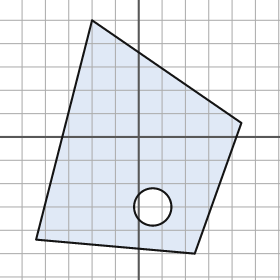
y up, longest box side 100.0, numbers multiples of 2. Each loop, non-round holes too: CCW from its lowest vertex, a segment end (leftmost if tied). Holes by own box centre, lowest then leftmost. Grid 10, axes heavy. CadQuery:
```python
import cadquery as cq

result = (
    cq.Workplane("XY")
    .moveTo(24.0, -50.0)
    .lineTo(44.0, 6.0)
    .lineTo(-20.0, 50.0)
    .lineTo(-44.0, -44.0)
    .close()
    .moveTo(6.0, -30.0)
    .circle(8.0)
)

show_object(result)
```